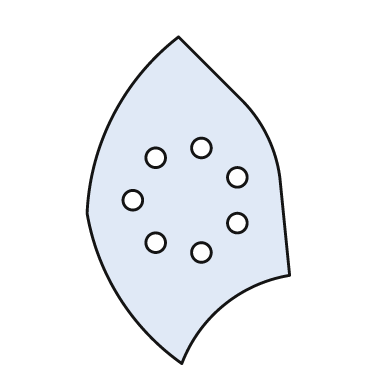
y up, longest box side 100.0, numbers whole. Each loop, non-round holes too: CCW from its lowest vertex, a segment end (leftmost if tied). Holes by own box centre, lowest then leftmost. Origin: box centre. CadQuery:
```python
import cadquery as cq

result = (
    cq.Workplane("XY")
    .moveTo(-2.0, -50.0)
    .threePointArc((11.0, -32.0), (31.0, -23.0))
    .lineTo(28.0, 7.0)
    .threePointArc((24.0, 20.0), (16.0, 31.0))
    .lineTo(-3.0, 50.0)
    .threePointArc((-23.0, 26.0), (-31.0, -4.0))
    .threePointArc((-21.0, -30.0), (-2.0, -50.0))
    .close()
    .moveTo(4.0, -16.0)
    .circle(3.0)
    .moveTo(-10.0, -13.0)
    .circle(3.0)
    .moveTo(15.0, -7.0)
    .circle(3.0)
    .moveTo(-17.0, 0.0)
    .circle(3.0)
    .moveTo(15.0, 7.0)
    .circle(3.0)
    .moveTo(-10.0, 13.0)
    .circle(3.0)
    .moveTo(4.0, 16.0)
    .circle(3.0)
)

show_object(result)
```